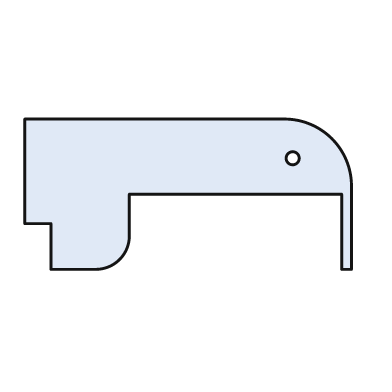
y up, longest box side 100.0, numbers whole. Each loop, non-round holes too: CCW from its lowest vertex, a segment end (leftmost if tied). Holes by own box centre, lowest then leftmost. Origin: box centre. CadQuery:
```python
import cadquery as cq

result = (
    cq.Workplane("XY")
    .moveTo(-42.0, -23.0)
    .lineTo(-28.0, -23.0)
    .threePointArc((-21.0, -20.0), (-18.0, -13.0))
    .lineTo(-18.0, 0.0)
    .lineTo(47.0, 0.0)
    .lineTo(47.0, -23.0)
    .lineTo(50.0, -23.0)
    .lineTo(50.0, 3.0)
    .threePointArc((44.0, 17.0), (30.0, 23.0))
    .lineTo(-50.0, 23.0)
    .lineTo(-50.0, -9.0)
    .lineTo(-42.0, -9.0)
    .close()
    .moveTo(32.0, 11.0)
    .circle(2.0)
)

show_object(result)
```